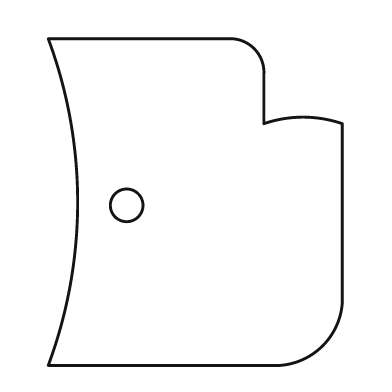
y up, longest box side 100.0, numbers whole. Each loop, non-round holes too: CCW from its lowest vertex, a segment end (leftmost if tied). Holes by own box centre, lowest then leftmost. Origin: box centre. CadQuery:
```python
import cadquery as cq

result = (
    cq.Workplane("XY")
    .moveTo(-45.0, -50.0)
    .lineTo(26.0, -50.0)
    .threePointArc((39.0, -44.0), (45.0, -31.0))
    .lineTo(45.0, 24.0)
    .threePointArc((33.0, 26.0), (21.0, 24.0))
    .lineTo(21.0, 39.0)
    .threePointArc((18.0, 47.0), (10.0, 50.0))
    .lineTo(-45.0, 50.0)
    .threePointArc((-36.0, 0.0), (-45.0, -50.0))
    .close()
    .moveTo(-21.0, -1.0)
    .circle(5.0)
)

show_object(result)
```